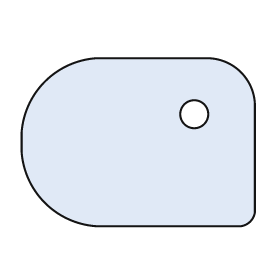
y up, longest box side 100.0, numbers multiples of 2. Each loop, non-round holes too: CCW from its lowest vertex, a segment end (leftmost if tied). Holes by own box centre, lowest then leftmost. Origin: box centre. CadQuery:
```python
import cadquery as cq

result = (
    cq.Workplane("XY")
    .moveTo(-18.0, -36.0)
    .lineTo(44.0, -36.0)
    .threePointArc((48.0, -34.0), (50.0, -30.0))
    .lineTo(50.0, 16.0)
    .threePointArc((44.0, 30.0), (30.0, 36.0))
    .lineTo(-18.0, 36.0)
    .threePointArc((-40.0, 26.0), (-50.0, 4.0))
    .lineTo(-50.0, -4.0)
    .threePointArc((-40.0, -26.0), (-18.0, -36.0))
    .close()
    .moveTo(24.0, 12.0)
    .circle(6.0)
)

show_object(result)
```